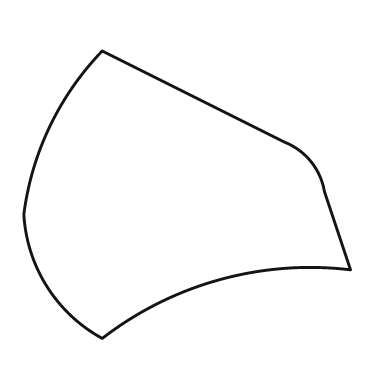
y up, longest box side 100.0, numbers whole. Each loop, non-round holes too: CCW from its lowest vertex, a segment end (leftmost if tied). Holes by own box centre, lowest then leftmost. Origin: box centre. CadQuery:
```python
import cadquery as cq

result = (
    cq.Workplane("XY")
    .moveTo(-26.0, -44.0)
    .threePointArc((10.0, -26.0), (50.0, -23.0))
    .lineTo(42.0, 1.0)
    .threePointArc((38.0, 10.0), (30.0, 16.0))
    .lineTo(-26.0, 44.0)
    .threePointArc((-42.0, 21.0), (-50.0, -6.0))
    .threePointArc((-43.0, -28.0), (-26.0, -44.0))
    .close()
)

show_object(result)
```